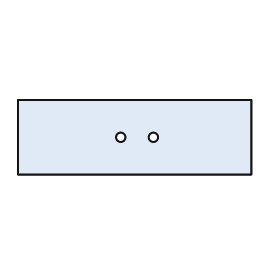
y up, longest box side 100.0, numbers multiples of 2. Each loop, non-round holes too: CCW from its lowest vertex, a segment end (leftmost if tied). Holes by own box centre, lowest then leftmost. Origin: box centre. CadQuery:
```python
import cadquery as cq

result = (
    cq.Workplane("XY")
    .moveTo(-50.0, -16.0)
    .lineTo(50.0, -16.0)
    .lineTo(50.0, 16.0)
    .lineTo(-50.0, 16.0)
    .close()
    .moveTo(-6.0, 0.0)
    .circle(2.0)
    .moveTo(8.0, 0.0)
    .circle(2.0)
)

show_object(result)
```